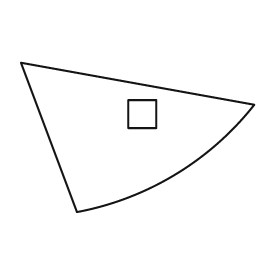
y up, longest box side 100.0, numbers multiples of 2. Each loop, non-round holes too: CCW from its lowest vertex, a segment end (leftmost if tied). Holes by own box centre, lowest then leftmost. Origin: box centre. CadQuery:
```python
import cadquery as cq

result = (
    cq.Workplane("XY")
    .moveTo(-26.0, -32.0)
    .threePointArc((16.0, -16.0), (50.0, 14.0))
    .lineTo(-50.0, 32.0)
    .close()
    .moveTo(-4.0, 4.0)
    .lineTo(8.0, 4.0)
    .lineTo(8.0, 16.0)
    .lineTo(-4.0, 16.0)
    .close()
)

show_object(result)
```